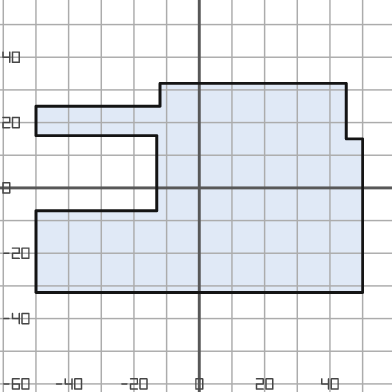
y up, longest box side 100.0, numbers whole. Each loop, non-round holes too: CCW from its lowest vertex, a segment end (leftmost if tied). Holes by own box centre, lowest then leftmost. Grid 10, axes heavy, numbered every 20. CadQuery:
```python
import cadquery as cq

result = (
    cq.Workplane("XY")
    .moveTo(-50.0, -32.0)
    .lineTo(50.0, -32.0)
    .lineTo(50.0, 15.0)
    .lineTo(45.0, 15.0)
    .lineTo(45.0, 32.0)
    .lineTo(-12.0, 32.0)
    .lineTo(-12.0, 25.0)
    .lineTo(-50.0, 25.0)
    .lineTo(-50.0, 16.0)
    .lineTo(-13.0, 16.0)
    .lineTo(-13.0, -7.0)
    .lineTo(-50.0, -7.0)
    .close()
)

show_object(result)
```